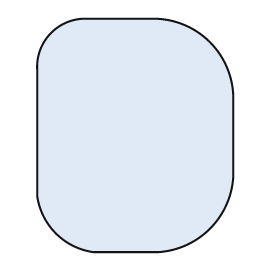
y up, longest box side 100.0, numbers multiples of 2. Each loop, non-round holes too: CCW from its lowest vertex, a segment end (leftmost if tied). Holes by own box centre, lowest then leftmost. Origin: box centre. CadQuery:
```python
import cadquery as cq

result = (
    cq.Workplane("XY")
    .moveTo(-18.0, -50.0)
    .lineTo(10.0, -50.0)
    .threePointArc((32.0, -40.0), (42.0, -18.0))
    .lineTo(42.0, 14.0)
    .threePointArc((32.0, 40.0), (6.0, 50.0))
    .lineTo(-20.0, 50.0)
    .threePointArc((-36.0, 44.0), (-42.0, 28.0))
    .lineTo(-42.0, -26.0)
    .threePointArc((-34.0, -42.0), (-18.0, -50.0))
    .close()
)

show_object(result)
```